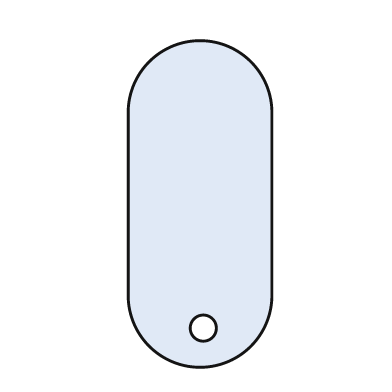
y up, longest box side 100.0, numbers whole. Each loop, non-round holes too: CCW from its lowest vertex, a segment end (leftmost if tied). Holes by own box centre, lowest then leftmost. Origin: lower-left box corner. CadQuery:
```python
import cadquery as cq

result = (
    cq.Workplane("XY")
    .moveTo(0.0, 22.0)
    .threePointArc((22.0, 0.0), (44.0, 22.0))
    .lineTo(44.0, 78.0)
    .threePointArc((22.0, 100.0), (0.0, 78.0))
    .close()
    .moveTo(23.0, 12.0)
    .circle(4.0)
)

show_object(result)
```